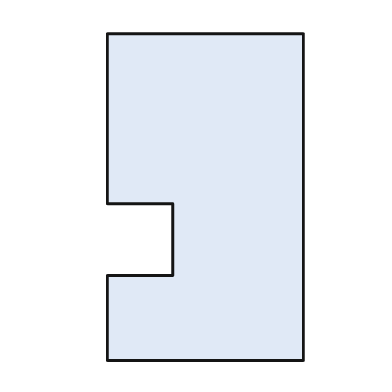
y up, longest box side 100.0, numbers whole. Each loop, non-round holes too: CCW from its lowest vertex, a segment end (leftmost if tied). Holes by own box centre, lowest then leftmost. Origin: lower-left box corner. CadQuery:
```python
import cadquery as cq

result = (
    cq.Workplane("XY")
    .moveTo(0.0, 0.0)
    .lineTo(60.0, 0.0)
    .lineTo(60.0, 100.0)
    .lineTo(0.0, 100.0)
    .lineTo(0.0, 48.0)
    .lineTo(20.0, 48.0)
    .lineTo(20.0, 26.0)
    .lineTo(0.0, 26.0)
    .close()
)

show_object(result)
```